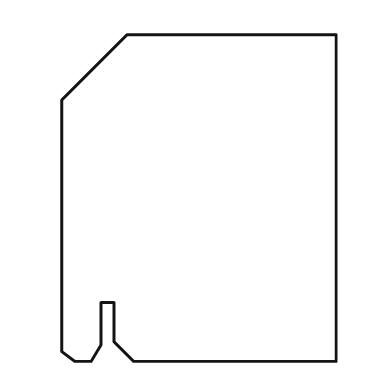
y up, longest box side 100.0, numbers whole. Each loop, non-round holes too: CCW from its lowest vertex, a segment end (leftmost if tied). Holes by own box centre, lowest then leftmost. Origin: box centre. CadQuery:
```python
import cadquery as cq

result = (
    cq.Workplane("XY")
    .moveTo(-38.0, -50.0)
    .lineTo(-33.0, -50.0)
    .lineTo(-30.0, -45.0)
    .lineTo(-30.0, -32.0)
    .lineTo(-26.0, -32.0)
    .lineTo(-26.0, -44.0)
    .lineTo(-20.0, -50.0)
    .lineTo(42.0, -50.0)
    .lineTo(42.0, 50.0)
    .lineTo(-22.0, 50.0)
    .lineTo(-42.0, 30.0)
    .lineTo(-42.0, -47.0)
    .close()
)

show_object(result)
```